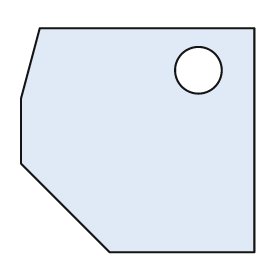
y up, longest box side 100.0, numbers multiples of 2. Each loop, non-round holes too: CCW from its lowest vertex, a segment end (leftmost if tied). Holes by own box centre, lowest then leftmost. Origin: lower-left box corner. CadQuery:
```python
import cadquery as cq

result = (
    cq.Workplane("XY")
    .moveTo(38.0, 0.0)
    .lineTo(100.0, 0.0)
    .lineTo(100.0, 96.0)
    .lineTo(8.0, 96.0)
    .lineTo(0.0, 66.0)
    .lineTo(0.0, 38.0)
    .close()
    .moveTo(76.0, 78.0)
    .circle(10.0)
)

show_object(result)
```